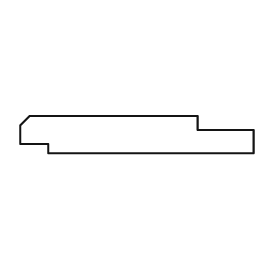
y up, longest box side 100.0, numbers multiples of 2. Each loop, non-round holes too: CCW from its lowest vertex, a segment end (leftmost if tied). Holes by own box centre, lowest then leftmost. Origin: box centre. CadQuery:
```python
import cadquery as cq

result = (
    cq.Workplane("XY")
    .moveTo(-38.0, -8.0)
    .lineTo(50.0, -8.0)
    .lineTo(50.0, 2.0)
    .lineTo(26.0, 2.0)
    .lineTo(26.0, 8.0)
    .lineTo(-46.0, 8.0)
    .lineTo(-50.0, 4.0)
    .lineTo(-50.0, -4.0)
    .lineTo(-38.0, -4.0)
    .close()
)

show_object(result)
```